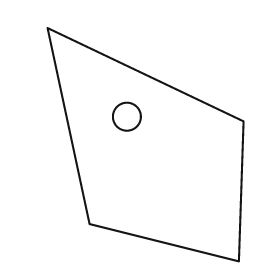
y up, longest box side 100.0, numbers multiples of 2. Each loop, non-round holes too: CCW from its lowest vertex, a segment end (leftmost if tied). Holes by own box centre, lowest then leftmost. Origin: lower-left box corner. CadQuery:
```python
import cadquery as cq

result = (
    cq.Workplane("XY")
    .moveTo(82.0, 0.0)
    .lineTo(84.0, 60.0)
    .lineTo(0.0, 100.0)
    .lineTo(18.0, 16.0)
    .close()
    .moveTo(34.0, 62.0)
    .circle(6.0)
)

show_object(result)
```